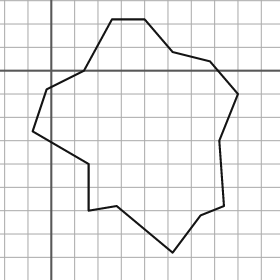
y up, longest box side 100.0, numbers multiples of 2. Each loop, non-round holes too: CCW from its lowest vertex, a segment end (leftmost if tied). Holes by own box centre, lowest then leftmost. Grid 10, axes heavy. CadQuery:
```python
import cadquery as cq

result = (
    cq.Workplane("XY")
    .moveTo(52.0, -78.0)
    .lineTo(64.0, -62.0)
    .lineTo(74.0, -58.0)
    .lineTo(72.0, -30.0)
    .lineTo(80.0, -10.0)
    .lineTo(68.0, 4.0)
    .lineTo(52.0, 8.0)
    .lineTo(40.0, 22.0)
    .lineTo(26.0, 22.0)
    .lineTo(14.0, 0.0)
    .lineTo(-2.0, -8.0)
    .lineTo(-8.0, -26.0)
    .lineTo(16.0, -40.0)
    .lineTo(16.0, -60.0)
    .lineTo(28.0, -58.0)
    .close()
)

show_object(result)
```